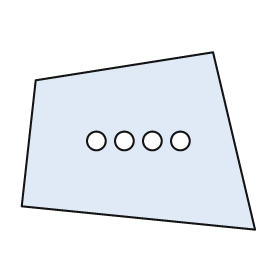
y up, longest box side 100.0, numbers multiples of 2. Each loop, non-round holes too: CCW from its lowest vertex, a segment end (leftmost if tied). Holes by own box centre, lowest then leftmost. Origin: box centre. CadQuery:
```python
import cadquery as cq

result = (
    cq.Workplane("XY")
    .moveTo(50.0, -38.0)
    .lineTo(32.0, 38.0)
    .lineTo(-44.0, 26.0)
    .lineTo(-50.0, -28.0)
    .close()
    .moveTo(-18.0, 0.0)
    .circle(4.0)
    .moveTo(-6.0, 0.0)
    .circle(4.0)
    .moveTo(6.0, 0.0)
    .circle(4.0)
    .moveTo(18.0, 0.0)
    .circle(4.0)
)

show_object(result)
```